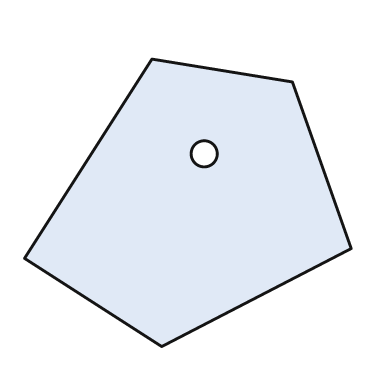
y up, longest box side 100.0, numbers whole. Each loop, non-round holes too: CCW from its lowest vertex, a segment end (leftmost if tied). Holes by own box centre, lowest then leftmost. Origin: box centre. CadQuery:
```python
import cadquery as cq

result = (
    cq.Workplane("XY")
    .moveTo(-8.0, -44.0)
    .lineTo(50.0, -14.0)
    .lineTo(32.0, 37.0)
    .lineTo(-11.0, 44.0)
    .lineTo(-50.0, -17.0)
    .close()
    .moveTo(5.0, 15.0)
    .circle(4.0)
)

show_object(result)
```